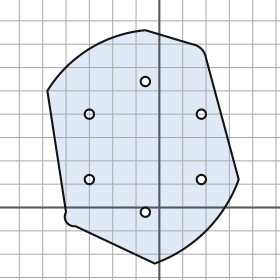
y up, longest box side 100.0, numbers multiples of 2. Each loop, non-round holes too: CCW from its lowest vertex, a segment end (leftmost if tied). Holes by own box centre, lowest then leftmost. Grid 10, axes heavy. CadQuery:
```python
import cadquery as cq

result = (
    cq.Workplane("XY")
    .moveTo(-2.0, -24.0)
    .threePointArc((20.0, -10.0), (34.0, 12.0))
    .lineTo(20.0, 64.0)
    .threePointArc((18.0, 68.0), (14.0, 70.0))
    .lineTo(-6.0, 76.0)
    .threePointArc((-30.0, 68.0), (-48.0, 50.0))
    .lineTo(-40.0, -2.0)
    .threePointArc((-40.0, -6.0), (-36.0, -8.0))
    .close()
    .moveTo(-6.0, -2.0)
    .circle(2.0)
    .moveTo(-30.0, 12.0)
    .circle(2.0)
    .moveTo(18.0, 12.0)
    .circle(2.0)
    .moveTo(-30.0, 40.0)
    .circle(2.0)
    .moveTo(18.0, 40.0)
    .circle(2.0)
    .moveTo(-6.0, 54.0)
    .circle(2.0)
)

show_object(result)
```